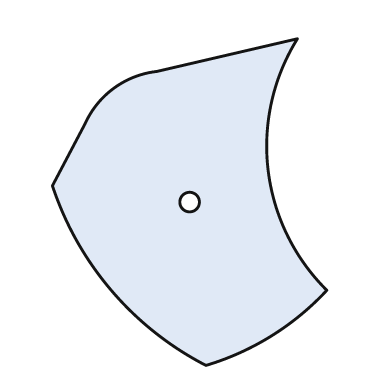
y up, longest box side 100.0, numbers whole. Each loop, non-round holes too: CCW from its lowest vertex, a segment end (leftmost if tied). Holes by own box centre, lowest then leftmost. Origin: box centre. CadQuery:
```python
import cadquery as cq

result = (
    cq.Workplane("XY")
    .moveTo(5.0, -50.0)
    .threePointArc((25.0, -41.0), (42.0, -27.0))
    .threePointArc((24.0, 10.0), (33.0, 50.0))
    .lineTo(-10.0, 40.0)
    .threePointArc((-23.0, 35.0), (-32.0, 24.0))
    .lineTo(-42.0, 5.0)
    .threePointArc((-24.0, -27.0), (5.0, -50.0))
    .close()
    .moveTo(0.0, 0.0)
    .circle(3.0)
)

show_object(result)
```